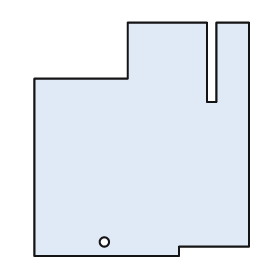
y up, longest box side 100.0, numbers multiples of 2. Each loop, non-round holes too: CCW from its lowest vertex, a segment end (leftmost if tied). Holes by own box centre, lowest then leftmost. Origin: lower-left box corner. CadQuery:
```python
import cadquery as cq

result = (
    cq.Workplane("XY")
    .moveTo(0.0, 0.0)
    .lineTo(62.0, 0.0)
    .lineTo(62.0, 4.0)
    .lineTo(92.0, 4.0)
    .lineTo(92.0, 100.0)
    .lineTo(78.0, 100.0)
    .lineTo(78.0, 66.0)
    .lineTo(74.0, 66.0)
    .lineTo(74.0, 100.0)
    .lineTo(40.0, 100.0)
    .lineTo(40.0, 76.0)
    .lineTo(0.0, 76.0)
    .close()
    .moveTo(30.0, 6.0)
    .circle(2.0)
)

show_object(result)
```